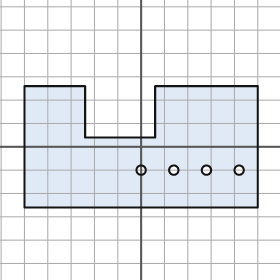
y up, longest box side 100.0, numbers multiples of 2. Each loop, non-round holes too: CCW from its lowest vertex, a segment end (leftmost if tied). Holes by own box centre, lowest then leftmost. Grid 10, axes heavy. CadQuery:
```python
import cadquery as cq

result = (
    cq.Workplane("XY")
    .moveTo(-50.0, -26.0)
    .lineTo(50.0, -26.0)
    .lineTo(50.0, 26.0)
    .lineTo(6.0, 26.0)
    .lineTo(6.0, 4.0)
    .lineTo(-24.0, 4.0)
    .lineTo(-24.0, 26.0)
    .lineTo(-50.0, 26.0)
    .close()
    .moveTo(0.0, -10.0)
    .circle(2.0)
    .moveTo(14.0, -10.0)
    .circle(2.0)
    .moveTo(28.0, -10.0)
    .circle(2.0)
    .moveTo(42.0, -10.0)
    .circle(2.0)
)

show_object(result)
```